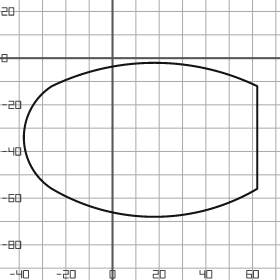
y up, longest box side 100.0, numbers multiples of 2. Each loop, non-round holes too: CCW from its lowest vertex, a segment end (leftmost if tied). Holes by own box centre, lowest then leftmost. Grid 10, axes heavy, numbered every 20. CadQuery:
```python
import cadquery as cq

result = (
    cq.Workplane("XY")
    .moveTo(-26.0, -56.0)
    .threePointArc((18.0, -68.0), (62.0, -56.0))
    .lineTo(62.0, -12.0)
    .threePointArc((18.0, -2.0), (-26.0, -12.0))
    .threePointArc((-38.0, -34.0), (-26.0, -56.0))
    .close()
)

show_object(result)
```